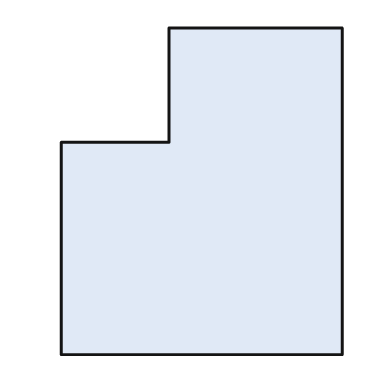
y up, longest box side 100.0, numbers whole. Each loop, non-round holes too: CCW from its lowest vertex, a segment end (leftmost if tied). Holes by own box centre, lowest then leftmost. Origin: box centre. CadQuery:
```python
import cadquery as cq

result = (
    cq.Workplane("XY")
    .moveTo(-43.0, -50.0)
    .lineTo(43.0, -50.0)
    .lineTo(43.0, 50.0)
    .lineTo(-10.0, 50.0)
    .lineTo(-10.0, 15.0)
    .lineTo(-43.0, 15.0)
    .close()
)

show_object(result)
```